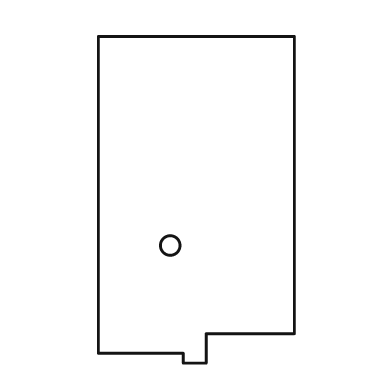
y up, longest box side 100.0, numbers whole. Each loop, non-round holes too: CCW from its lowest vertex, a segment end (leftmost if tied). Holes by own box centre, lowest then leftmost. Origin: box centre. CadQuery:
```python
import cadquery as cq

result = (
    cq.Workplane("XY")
    .moveTo(-4.0, -50.0)
    .lineTo(3.0, -50.0)
    .lineTo(3.0, -41.0)
    .lineTo(30.0, -41.0)
    .lineTo(30.0, 50.0)
    .lineTo(-30.0, 50.0)
    .lineTo(-30.0, -47.0)
    .lineTo(-4.0, -47.0)
    .close()
    .moveTo(-8.0, -14.0)
    .circle(3.0)
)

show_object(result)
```